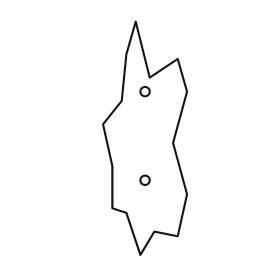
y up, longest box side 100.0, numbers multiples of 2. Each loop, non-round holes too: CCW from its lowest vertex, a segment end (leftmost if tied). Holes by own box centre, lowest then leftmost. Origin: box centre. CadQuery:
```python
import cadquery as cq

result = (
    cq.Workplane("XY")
    .moveTo(-2.0, -50.0)
    .lineTo(4.0, -40.0)
    .lineTo(14.0, -42.0)
    .lineTo(18.0, -24.0)
    .lineTo(12.0, -2.0)
    .lineTo(18.0, 20.0)
    .lineTo(14.0, 34.0)
    .lineTo(2.0, 26.0)
    .lineTo(-4.0, 50.0)
    .lineTo(-8.0, 36.0)
    .lineTo(-10.0, 16.0)
    .lineTo(-18.0, 6.0)
    .lineTo(-14.0, -12.0)
    .lineTo(-14.0, -30.0)
    .lineTo(-8.0, -32.0)
    .close()
    .moveTo(0.0, -18.0)
    .circle(2.0)
    .moveTo(0.0, 20.0)
    .circle(2.0)
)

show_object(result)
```